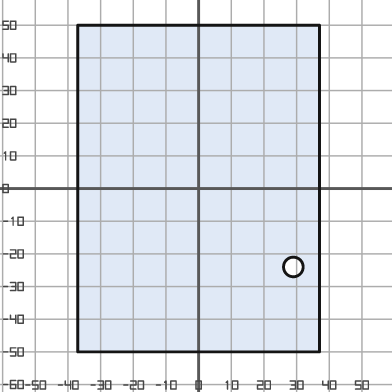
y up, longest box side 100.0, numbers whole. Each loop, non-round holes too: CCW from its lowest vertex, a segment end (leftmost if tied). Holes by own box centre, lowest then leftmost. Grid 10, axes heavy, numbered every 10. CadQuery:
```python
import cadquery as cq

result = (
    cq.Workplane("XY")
    .moveTo(-37.0, -50.0)
    .lineTo(37.0, -50.0)
    .lineTo(37.0, 50.0)
    .lineTo(-37.0, 50.0)
    .close()
    .moveTo(29.0, -24.0)
    .circle(3.0)
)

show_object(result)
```